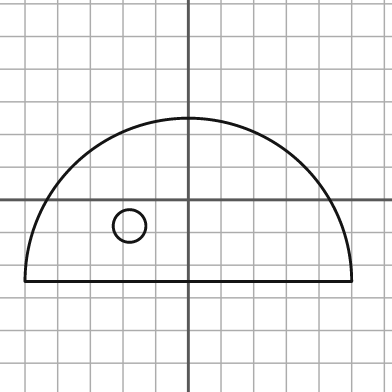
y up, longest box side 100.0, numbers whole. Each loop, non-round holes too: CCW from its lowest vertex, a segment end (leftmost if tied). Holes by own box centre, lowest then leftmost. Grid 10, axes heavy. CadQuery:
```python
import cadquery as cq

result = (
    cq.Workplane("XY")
    .moveTo(-50.0, -25.0)
    .lineTo(50.0, -25.0)
    .threePointArc((0.0, 25.0), (-50.0, -25.0))
    .close()
    .moveTo(-18.0, -8.0)
    .circle(5.0)
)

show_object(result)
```